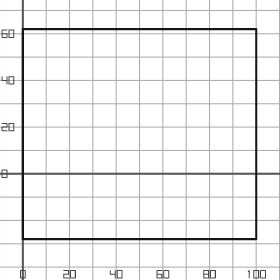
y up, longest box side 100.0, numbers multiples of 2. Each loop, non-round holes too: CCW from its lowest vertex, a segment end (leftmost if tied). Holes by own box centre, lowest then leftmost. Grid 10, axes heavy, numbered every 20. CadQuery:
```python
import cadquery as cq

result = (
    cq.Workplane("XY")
    .moveTo(0.0, -28.0)
    .lineTo(100.0, -28.0)
    .lineTo(100.0, 62.0)
    .lineTo(0.0, 62.0)
    .close()
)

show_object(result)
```